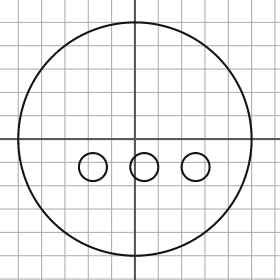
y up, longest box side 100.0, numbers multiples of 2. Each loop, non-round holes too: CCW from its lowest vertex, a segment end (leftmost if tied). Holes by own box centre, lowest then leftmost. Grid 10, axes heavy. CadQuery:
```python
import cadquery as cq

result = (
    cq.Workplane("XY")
    .moveTo(0.0, 0.0)
    .circle(50.0)
    .moveTo(-18.0, -12.0)
    .circle(6.0)
    .moveTo(4.0, -12.0)
    .circle(6.0)
    .moveTo(26.0, -12.0)
    .circle(6.0)
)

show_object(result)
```